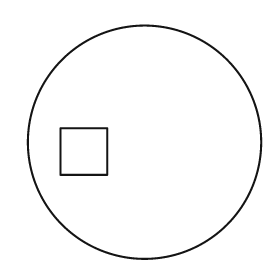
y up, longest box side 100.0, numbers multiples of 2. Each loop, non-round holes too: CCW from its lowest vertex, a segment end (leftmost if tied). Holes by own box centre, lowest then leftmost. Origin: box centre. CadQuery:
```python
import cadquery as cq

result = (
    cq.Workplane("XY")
    .moveTo(0.0, 0.0)
    .circle(50.0)
    .moveTo(-36.0, -14.0)
    .lineTo(-16.0, -14.0)
    .lineTo(-16.0, 6.0)
    .lineTo(-36.0, 6.0)
    .close()
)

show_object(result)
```